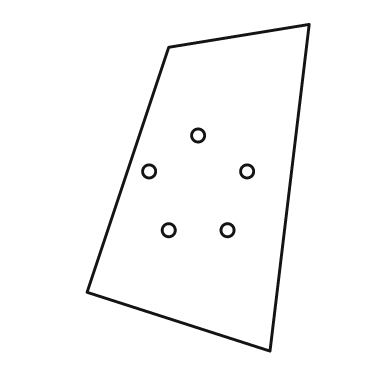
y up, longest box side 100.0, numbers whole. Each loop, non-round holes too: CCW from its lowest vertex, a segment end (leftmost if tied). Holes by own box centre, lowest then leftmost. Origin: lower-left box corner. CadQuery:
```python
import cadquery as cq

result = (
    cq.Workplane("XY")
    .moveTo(56.0, 0.0)
    .lineTo(68.0, 100.0)
    .lineTo(25.0, 93.0)
    .lineTo(0.0, 18.0)
    .close()
    .moveTo(25.0, 37.0)
    .circle(2.0)
    .moveTo(43.0, 37.0)
    .circle(2.0)
    .moveTo(19.0, 55.0)
    .circle(2.0)
    .moveTo(49.0, 55.0)
    .circle(2.0)
    .moveTo(34.0, 66.0)
    .circle(2.0)
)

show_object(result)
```